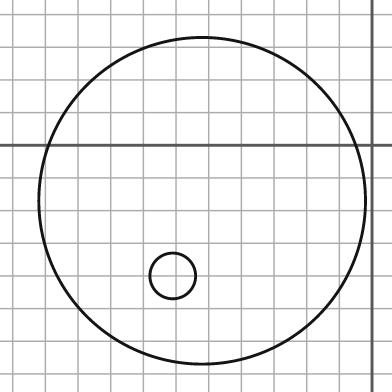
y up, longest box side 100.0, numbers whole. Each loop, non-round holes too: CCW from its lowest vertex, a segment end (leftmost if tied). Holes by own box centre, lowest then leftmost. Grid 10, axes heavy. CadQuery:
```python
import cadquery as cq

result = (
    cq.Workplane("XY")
    .moveTo(-52.0, -17.0)
    .circle(50.0)
    .moveTo(-61.0, -40.0)
    .circle(7.0)
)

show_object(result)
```